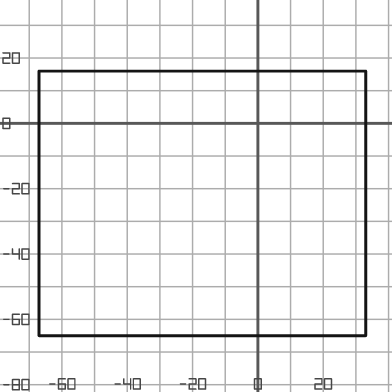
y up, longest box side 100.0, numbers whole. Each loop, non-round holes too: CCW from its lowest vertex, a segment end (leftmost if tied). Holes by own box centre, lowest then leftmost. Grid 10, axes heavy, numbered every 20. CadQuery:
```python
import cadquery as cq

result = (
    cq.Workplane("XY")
    .moveTo(-67.0, -65.0)
    .lineTo(33.0, -65.0)
    .lineTo(33.0, 16.0)
    .lineTo(-67.0, 16.0)
    .close()
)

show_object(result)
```